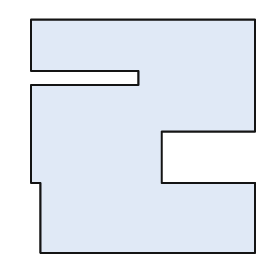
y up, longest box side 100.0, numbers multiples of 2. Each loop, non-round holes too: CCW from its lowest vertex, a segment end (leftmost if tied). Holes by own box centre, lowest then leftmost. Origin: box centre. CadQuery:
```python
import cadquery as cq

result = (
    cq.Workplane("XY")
    .moveTo(-44.0, -50.0)
    .lineTo(48.0, -50.0)
    .lineTo(48.0, -20.0)
    .lineTo(8.0, -20.0)
    .lineTo(8.0, 2.0)
    .lineTo(48.0, 2.0)
    .lineTo(48.0, 50.0)
    .lineTo(-48.0, 50.0)
    .lineTo(-48.0, 28.0)
    .lineTo(-2.0, 28.0)
    .lineTo(-2.0, 22.0)
    .lineTo(-48.0, 22.0)
    .lineTo(-48.0, -20.0)
    .lineTo(-44.0, -20.0)
    .close()
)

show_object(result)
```